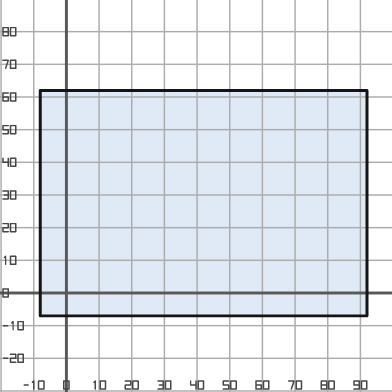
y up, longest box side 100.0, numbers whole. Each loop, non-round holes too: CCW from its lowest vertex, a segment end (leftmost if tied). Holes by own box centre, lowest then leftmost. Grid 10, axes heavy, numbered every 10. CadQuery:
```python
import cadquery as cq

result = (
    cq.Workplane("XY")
    .moveTo(-8.0, -7.0)
    .lineTo(92.0, -7.0)
    .lineTo(92.0, 62.0)
    .lineTo(-8.0, 62.0)
    .close()
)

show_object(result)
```